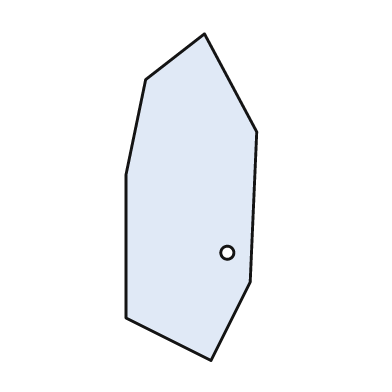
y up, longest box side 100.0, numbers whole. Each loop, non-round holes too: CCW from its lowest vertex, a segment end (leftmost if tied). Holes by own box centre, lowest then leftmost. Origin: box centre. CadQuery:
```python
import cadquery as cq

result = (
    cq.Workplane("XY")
    .moveTo(6.0, -50.0)
    .lineTo(18.0, -26.0)
    .lineTo(20.0, 20.0)
    .lineTo(4.0, 50.0)
    .lineTo(-14.0, 36.0)
    .lineTo(-20.0, 7.0)
    .lineTo(-20.0, -37.0)
    .close()
    .moveTo(11.0, -17.0)
    .circle(2.0)
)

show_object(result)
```